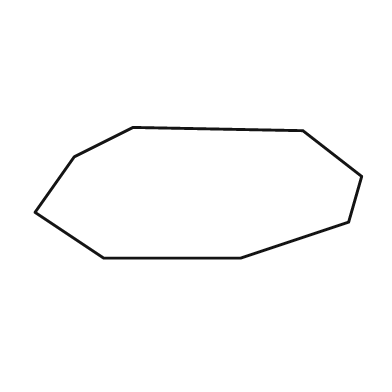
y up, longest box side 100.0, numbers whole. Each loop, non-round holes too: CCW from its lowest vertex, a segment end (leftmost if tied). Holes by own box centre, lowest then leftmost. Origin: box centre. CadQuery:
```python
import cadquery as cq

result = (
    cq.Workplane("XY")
    .moveTo(-29.0, -20.0)
    .lineTo(13.0, -20.0)
    .lineTo(46.0, -9.0)
    .lineTo(50.0, 5.0)
    .lineTo(32.0, 19.0)
    .lineTo(-20.0, 20.0)
    .lineTo(-38.0, 11.0)
    .lineTo(-50.0, -6.0)
    .close()
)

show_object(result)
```